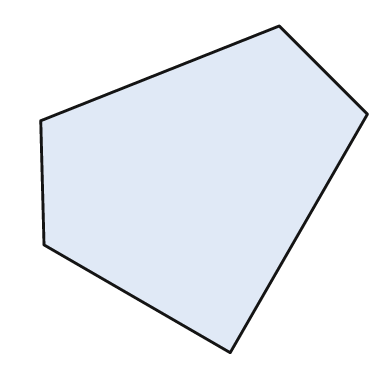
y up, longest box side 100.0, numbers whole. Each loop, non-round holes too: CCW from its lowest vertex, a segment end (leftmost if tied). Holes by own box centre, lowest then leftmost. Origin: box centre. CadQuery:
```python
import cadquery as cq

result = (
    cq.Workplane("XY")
    .moveTo(8.0, -50.0)
    .lineTo(50.0, 23.0)
    .lineTo(23.0, 50.0)
    .lineTo(-50.0, 21.0)
    .lineTo(-49.0, -17.0)
    .close()
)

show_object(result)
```